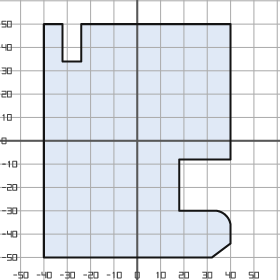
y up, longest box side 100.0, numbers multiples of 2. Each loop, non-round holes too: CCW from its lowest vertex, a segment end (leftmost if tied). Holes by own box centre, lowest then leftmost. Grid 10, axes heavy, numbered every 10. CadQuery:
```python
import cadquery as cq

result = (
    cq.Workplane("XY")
    .moveTo(-40.0, -50.0)
    .lineTo(32.0, -50.0)
    .lineTo(40.0, -44.0)
    .lineTo(40.0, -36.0)
    .threePointArc((38.0, -32.0), (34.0, -30.0))
    .lineTo(18.0, -30.0)
    .lineTo(18.0, -8.0)
    .lineTo(40.0, -8.0)
    .lineTo(40.0, 50.0)
    .lineTo(-24.0, 50.0)
    .lineTo(-24.0, 34.0)
    .lineTo(-32.0, 34.0)
    .lineTo(-32.0, 50.0)
    .lineTo(-40.0, 50.0)
    .close()
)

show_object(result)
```